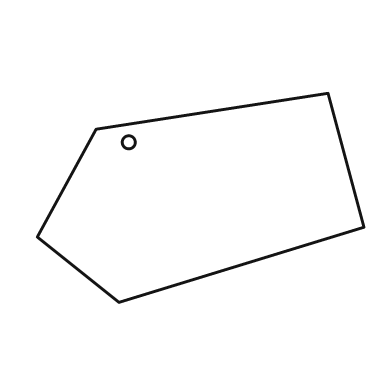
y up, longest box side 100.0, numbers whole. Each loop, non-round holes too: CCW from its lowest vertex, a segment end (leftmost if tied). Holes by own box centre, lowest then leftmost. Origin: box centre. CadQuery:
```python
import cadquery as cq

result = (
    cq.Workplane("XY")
    .moveTo(-25.0, -32.0)
    .lineTo(50.0, -9.0)
    .lineTo(39.0, 32.0)
    .lineTo(-32.0, 21.0)
    .lineTo(-50.0, -12.0)
    .close()
    .moveTo(-22.0, 17.0)
    .circle(2.0)
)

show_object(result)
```